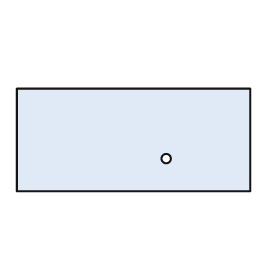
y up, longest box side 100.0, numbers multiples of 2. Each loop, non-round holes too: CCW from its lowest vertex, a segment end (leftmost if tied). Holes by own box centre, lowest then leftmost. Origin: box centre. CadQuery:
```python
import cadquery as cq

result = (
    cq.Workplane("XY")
    .moveTo(-50.0, -22.0)
    .lineTo(50.0, -22.0)
    .lineTo(50.0, 22.0)
    .lineTo(-50.0, 22.0)
    .close()
    .moveTo(14.0, -8.0)
    .circle(2.0)
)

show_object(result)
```